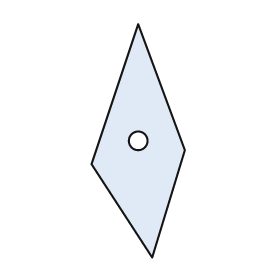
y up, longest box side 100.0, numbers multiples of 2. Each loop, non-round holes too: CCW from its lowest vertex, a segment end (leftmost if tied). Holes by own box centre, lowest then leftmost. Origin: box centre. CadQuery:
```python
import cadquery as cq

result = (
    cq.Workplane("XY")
    .moveTo(6.0, -50.0)
    .lineTo(20.0, -4.0)
    .lineTo(0.0, 50.0)
    .lineTo(-20.0, -10.0)
    .close()
    .moveTo(0.0, 0.0)
    .circle(4.0)
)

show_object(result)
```